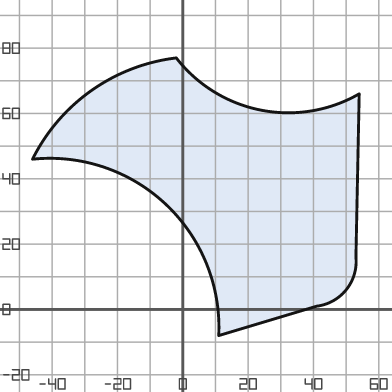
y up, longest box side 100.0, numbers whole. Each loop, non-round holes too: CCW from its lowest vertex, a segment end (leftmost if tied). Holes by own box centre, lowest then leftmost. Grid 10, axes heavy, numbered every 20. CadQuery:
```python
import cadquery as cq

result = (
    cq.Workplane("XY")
    .moveTo(11.0, -8.0)
    .lineTo(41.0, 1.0)
    .threePointArc((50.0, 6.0), (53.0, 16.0))
    .lineTo(54.0, 66.0)
    .threePointArc((24.0, 61.0), (-2.0, 77.0))
    .threePointArc((-28.0, 67.0), (-46.0, 46.0))
    .threePointArc((-5.0, 32.0), (11.0, -8.0))
    .close()
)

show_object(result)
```